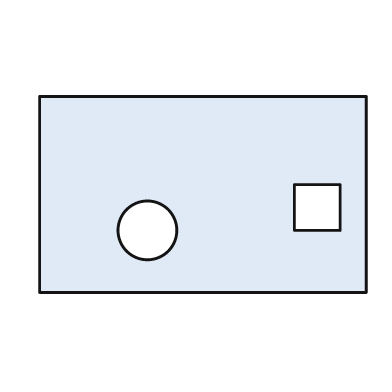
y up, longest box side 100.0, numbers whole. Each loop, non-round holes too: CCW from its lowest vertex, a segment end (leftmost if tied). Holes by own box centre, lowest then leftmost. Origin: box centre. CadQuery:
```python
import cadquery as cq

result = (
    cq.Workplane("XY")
    .moveTo(-50.0, -30.0)
    .lineTo(50.0, -30.0)
    .lineTo(50.0, 30.0)
    .lineTo(-50.0, 30.0)
    .close()
    .moveTo(-17.0, -11.0)
    .circle(9.0)
    .moveTo(28.0, -11.0)
    .lineTo(42.0, -11.0)
    .lineTo(42.0, 3.0)
    .lineTo(28.0, 3.0)
    .close()
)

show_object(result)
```